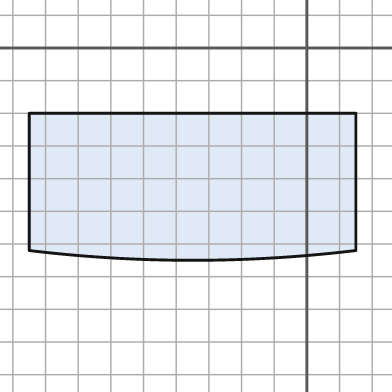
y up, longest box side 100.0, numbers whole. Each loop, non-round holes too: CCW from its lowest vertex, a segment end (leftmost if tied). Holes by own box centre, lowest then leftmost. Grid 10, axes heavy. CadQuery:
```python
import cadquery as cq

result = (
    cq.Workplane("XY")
    .moveTo(-85.0, -62.0)
    .threePointArc((-35.0, -65.0), (15.0, -62.0))
    .lineTo(15.0, -20.0)
    .lineTo(-85.0, -20.0)
    .close()
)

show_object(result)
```